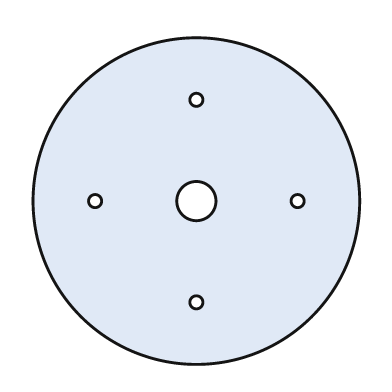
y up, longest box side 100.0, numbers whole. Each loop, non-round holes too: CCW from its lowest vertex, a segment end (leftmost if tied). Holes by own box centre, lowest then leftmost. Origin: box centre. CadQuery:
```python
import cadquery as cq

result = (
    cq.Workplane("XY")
    .moveTo(0.0, 0.0)
    .circle(50.0)
    .moveTo(0.0, -31.0)
    .circle(2.0)
    .moveTo(-31.0, 0.0)
    .circle(2.0)
    .moveTo(0.0, 0.0)
    .circle(6.0)
    .moveTo(31.0, 0.0)
    .circle(2.0)
    .moveTo(0.0, 31.0)
    .circle(2.0)
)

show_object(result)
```